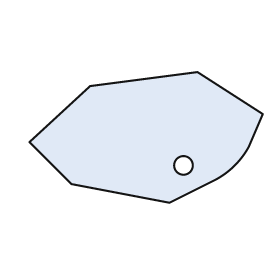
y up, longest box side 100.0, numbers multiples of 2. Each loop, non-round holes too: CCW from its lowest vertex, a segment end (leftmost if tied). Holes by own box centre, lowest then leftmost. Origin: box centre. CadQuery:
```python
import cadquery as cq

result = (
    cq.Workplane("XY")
    .moveTo(10.0, -28.0)
    .lineTo(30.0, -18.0)
    .threePointArc((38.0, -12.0), (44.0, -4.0))
    .lineTo(50.0, 10.0)
    .lineTo(22.0, 28.0)
    .lineTo(-24.0, 22.0)
    .lineTo(-50.0, -2.0)
    .lineTo(-32.0, -20.0)
    .close()
    .moveTo(16.0, -12.0)
    .circle(4.0)
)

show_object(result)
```